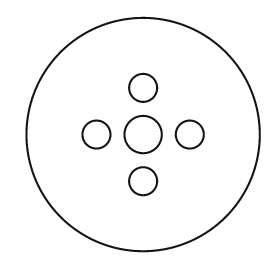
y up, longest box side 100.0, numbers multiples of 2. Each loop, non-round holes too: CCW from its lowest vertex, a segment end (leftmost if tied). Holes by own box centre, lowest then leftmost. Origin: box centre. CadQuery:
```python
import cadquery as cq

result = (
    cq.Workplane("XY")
    .moveTo(0.0, 0.0)
    .circle(50.0)
    .moveTo(0.0, -20.0)
    .circle(6.0)
    .moveTo(-20.0, 0.0)
    .circle(6.0)
    .moveTo(0.0, 0.0)
    .circle(8.0)
    .moveTo(20.0, 0.0)
    .circle(6.0)
    .moveTo(0.0, 20.0)
    .circle(6.0)
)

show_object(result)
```